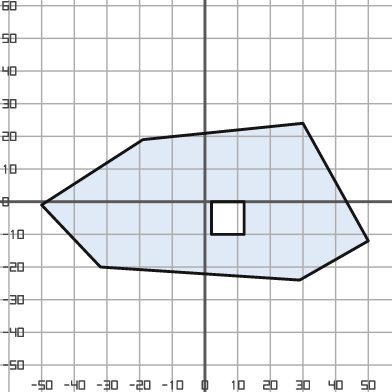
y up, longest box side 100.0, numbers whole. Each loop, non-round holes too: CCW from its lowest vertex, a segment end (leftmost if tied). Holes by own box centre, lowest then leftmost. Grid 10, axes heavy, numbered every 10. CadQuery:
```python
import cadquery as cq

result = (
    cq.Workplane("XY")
    .moveTo(29.0, -24.0)
    .lineTo(50.0, -12.0)
    .lineTo(30.0, 24.0)
    .lineTo(-19.0, 19.0)
    .lineTo(-50.0, -1.0)
    .lineTo(-32.0, -20.0)
    .close()
    .moveTo(2.0, -10.0)
    .lineTo(12.0, -10.0)
    .lineTo(12.0, 0.0)
    .lineTo(2.0, 0.0)
    .close()
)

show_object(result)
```